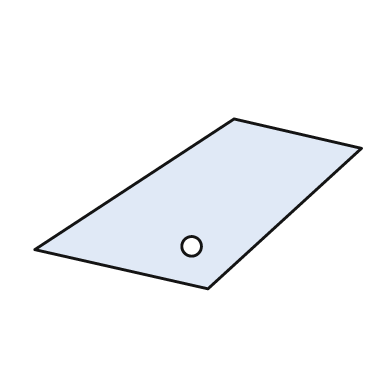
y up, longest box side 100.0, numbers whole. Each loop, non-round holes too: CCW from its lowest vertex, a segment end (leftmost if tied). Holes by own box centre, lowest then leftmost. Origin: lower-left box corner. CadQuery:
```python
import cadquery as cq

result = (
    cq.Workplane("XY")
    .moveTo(53.0, 0.0)
    .lineTo(100.0, 43.0)
    .lineTo(61.0, 52.0)
    .lineTo(0.0, 12.0)
    .close()
    .moveTo(48.0, 13.0)
    .circle(3.0)
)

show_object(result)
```